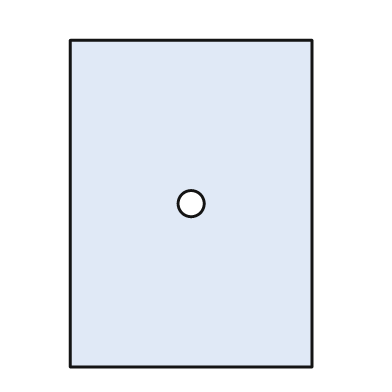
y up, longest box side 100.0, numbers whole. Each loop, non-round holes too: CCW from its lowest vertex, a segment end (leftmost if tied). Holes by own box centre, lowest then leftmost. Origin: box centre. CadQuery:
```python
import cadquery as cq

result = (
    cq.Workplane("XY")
    .moveTo(-37.0, -50.0)
    .lineTo(37.0, -50.0)
    .lineTo(37.0, 50.0)
    .lineTo(-37.0, 50.0)
    .close()
    .moveTo(0.0, 0.0)
    .circle(4.0)
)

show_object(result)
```